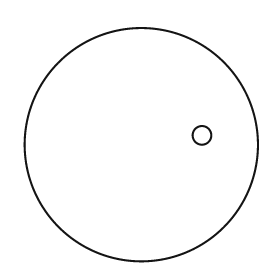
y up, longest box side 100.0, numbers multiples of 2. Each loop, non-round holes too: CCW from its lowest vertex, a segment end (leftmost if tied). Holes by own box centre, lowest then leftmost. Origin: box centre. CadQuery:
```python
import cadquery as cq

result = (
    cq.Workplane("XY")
    .moveTo(0.0, 0.0)
    .circle(50.0)
    .moveTo(26.0, 4.0)
    .circle(4.0)
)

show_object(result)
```